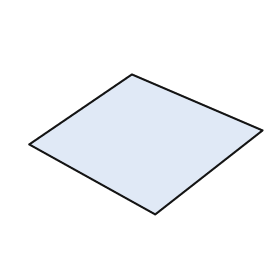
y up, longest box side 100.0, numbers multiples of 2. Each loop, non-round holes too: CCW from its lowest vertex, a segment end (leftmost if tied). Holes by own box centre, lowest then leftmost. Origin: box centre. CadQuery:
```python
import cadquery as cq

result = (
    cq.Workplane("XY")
    .moveTo(4.0, -30.0)
    .lineTo(50.0, 6.0)
    .lineTo(-6.0, 30.0)
    .lineTo(-50.0, 0.0)
    .close()
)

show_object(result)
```